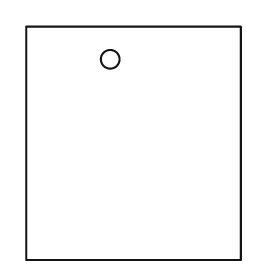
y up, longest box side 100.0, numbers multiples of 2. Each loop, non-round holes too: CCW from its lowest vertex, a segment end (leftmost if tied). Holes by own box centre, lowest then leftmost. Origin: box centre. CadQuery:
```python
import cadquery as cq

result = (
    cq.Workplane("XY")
    .moveTo(-46.0, -50.0)
    .lineTo(46.0, -50.0)
    .lineTo(46.0, 50.0)
    .lineTo(-46.0, 50.0)
    .close()
    .moveTo(-10.0, 36.0)
    .circle(4.0)
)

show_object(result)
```